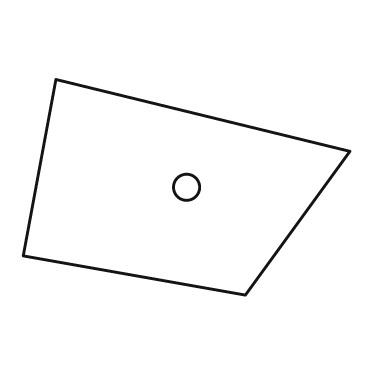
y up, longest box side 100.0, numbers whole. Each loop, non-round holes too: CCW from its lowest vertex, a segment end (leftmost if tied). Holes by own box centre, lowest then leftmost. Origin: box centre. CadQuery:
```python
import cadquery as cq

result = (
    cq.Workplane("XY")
    .moveTo(18.0, -33.0)
    .lineTo(50.0, 11.0)
    .lineTo(-40.0, 33.0)
    .lineTo(-50.0, -21.0)
    .close()
    .moveTo(0.0, 0.0)
    .circle(4.0)
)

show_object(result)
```